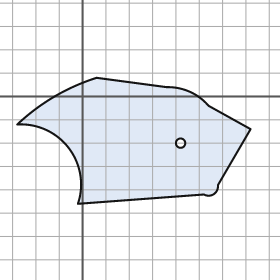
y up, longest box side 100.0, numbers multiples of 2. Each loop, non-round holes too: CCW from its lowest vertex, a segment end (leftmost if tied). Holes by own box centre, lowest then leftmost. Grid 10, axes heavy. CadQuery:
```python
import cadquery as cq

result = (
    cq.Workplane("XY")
    .moveTo(-2.0, -46.0)
    .lineTo(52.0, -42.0)
    .threePointArc((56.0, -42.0), (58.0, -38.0))
    .lineTo(72.0, -14.0)
    .lineTo(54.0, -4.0)
    .threePointArc((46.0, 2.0), (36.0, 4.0))
    .lineTo(6.0, 8.0)
    .threePointArc((-12.0, 0.0), (-28.0, -12.0))
    .threePointArc((-6.0, -22.0), (-2.0, -46.0))
    .close()
    .moveTo(42.0, -20.0)
    .circle(2.0)
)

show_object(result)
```